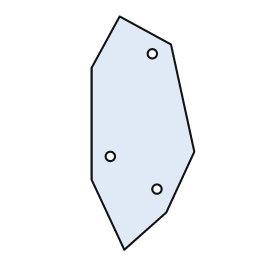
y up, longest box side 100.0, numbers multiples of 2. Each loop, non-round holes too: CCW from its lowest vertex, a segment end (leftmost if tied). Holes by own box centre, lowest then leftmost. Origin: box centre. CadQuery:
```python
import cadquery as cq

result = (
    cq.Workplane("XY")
    .moveTo(-8.0, -50.0)
    .lineTo(10.0, -34.0)
    .lineTo(22.0, -8.0)
    .lineTo(12.0, 38.0)
    .lineTo(-10.0, 50.0)
    .lineTo(-22.0, 28.0)
    .lineTo(-22.0, -20.0)
    .close()
    .moveTo(6.0, -24.0)
    .circle(2.0)
    .moveTo(-14.0, -10.0)
    .circle(2.0)
    .moveTo(4.0, 34.0)
    .circle(2.0)
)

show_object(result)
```